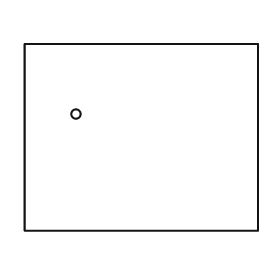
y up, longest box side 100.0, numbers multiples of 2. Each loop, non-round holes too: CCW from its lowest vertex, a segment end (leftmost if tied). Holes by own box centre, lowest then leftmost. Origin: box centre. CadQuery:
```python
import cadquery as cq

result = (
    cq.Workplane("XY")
    .moveTo(-50.0, -40.0)
    .lineTo(50.0, -40.0)
    .lineTo(50.0, 40.0)
    .lineTo(-50.0, 40.0)
    .close()
    .moveTo(-28.0, 10.0)
    .circle(2.0)
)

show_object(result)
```